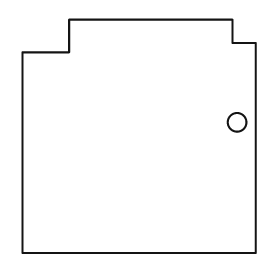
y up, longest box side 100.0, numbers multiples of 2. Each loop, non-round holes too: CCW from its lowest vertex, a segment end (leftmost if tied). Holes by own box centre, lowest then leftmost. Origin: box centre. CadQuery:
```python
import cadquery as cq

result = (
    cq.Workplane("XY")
    .moveTo(-50.0, -50.0)
    .lineTo(50.0, -50.0)
    .lineTo(50.0, 40.0)
    .lineTo(40.0, 40.0)
    .lineTo(40.0, 50.0)
    .lineTo(-30.0, 50.0)
    .lineTo(-30.0, 36.0)
    .lineTo(-50.0, 36.0)
    .close()
    .moveTo(42.0, 6.0)
    .circle(4.0)
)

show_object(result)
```